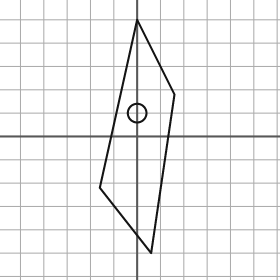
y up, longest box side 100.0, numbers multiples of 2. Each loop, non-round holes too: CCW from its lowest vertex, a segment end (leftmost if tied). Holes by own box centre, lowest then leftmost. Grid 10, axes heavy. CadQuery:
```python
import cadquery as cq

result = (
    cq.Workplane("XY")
    .moveTo(6.0, -50.0)
    .lineTo(16.0, 18.0)
    .lineTo(0.0, 50.0)
    .lineTo(-16.0, -22.0)
    .close()
    .moveTo(0.0, 10.0)
    .circle(4.0)
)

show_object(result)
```